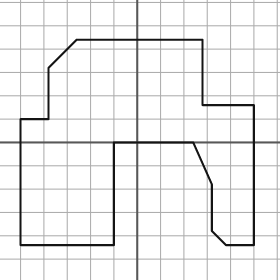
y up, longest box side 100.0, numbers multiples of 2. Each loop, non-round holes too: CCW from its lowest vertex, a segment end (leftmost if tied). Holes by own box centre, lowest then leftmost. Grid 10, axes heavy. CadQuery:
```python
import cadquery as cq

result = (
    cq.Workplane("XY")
    .moveTo(-50.0, -44.0)
    .lineTo(-10.0, -44.0)
    .lineTo(-10.0, 0.0)
    .lineTo(24.0, 0.0)
    .lineTo(32.0, -18.0)
    .lineTo(32.0, -38.0)
    .lineTo(38.0, -44.0)
    .lineTo(50.0, -44.0)
    .lineTo(50.0, 16.0)
    .lineTo(28.0, 16.0)
    .lineTo(28.0, 44.0)
    .lineTo(-26.0, 44.0)
    .lineTo(-38.0, 32.0)
    .lineTo(-38.0, 10.0)
    .lineTo(-50.0, 10.0)
    .close()
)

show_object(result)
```